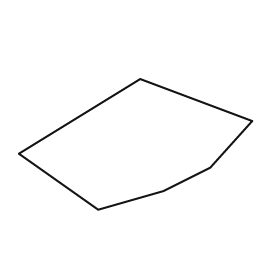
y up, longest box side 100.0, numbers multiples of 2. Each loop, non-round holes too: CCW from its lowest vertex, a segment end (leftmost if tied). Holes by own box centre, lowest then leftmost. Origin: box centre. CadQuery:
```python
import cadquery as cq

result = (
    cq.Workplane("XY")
    .moveTo(-16.0, -28.0)
    .lineTo(12.0, -20.0)
    .lineTo(32.0, -10.0)
    .lineTo(50.0, 10.0)
    .lineTo(2.0, 28.0)
    .lineTo(-50.0, -4.0)
    .close()
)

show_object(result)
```